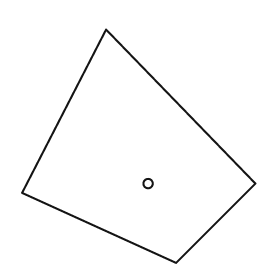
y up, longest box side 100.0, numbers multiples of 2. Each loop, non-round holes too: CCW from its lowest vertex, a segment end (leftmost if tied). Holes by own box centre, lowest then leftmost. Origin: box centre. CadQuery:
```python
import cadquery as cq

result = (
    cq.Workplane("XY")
    .moveTo(16.0, -50.0)
    .lineTo(50.0, -16.0)
    .lineTo(-14.0, 50.0)
    .lineTo(-50.0, -20.0)
    .close()
    .moveTo(4.0, -16.0)
    .circle(2.0)
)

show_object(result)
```